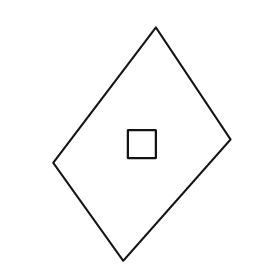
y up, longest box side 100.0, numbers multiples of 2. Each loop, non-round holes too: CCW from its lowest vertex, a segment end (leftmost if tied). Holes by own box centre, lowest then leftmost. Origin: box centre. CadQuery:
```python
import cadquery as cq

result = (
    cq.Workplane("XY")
    .moveTo(-8.0, -50.0)
    .lineTo(38.0, 2.0)
    .lineTo(6.0, 50.0)
    .lineTo(-38.0, -8.0)
    .close()
    .moveTo(-6.0, -6.0)
    .lineTo(6.0, -6.0)
    .lineTo(6.0, 6.0)
    .lineTo(-6.0, 6.0)
    .close()
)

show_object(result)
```